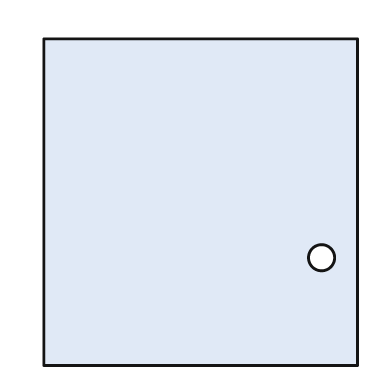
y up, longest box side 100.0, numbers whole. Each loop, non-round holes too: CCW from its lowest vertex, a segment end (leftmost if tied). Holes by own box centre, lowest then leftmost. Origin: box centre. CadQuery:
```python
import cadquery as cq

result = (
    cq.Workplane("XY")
    .moveTo(-48.0, -50.0)
    .lineTo(48.0, -50.0)
    .lineTo(48.0, 50.0)
    .lineTo(-48.0, 50.0)
    .close()
    .moveTo(37.0, -17.0)
    .circle(4.0)
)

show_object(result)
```